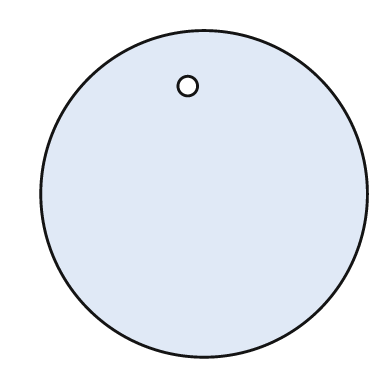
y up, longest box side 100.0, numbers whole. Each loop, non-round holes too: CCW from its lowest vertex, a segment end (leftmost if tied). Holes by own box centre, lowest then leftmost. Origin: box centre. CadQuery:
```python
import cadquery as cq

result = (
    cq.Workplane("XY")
    .moveTo(0.0, 0.0)
    .circle(50.0)
    .moveTo(-5.0, 33.0)
    .circle(3.0)
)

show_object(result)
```